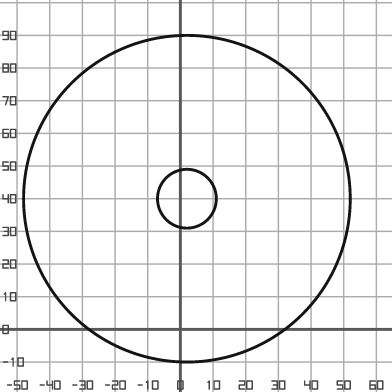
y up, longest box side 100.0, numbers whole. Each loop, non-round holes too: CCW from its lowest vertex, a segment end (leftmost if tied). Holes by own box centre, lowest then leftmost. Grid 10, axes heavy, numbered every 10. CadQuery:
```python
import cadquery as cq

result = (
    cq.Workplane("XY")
    .moveTo(2.0, 40.0)
    .circle(50.0)
    .moveTo(2.0, 40.0)
    .circle(9.0)
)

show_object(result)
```